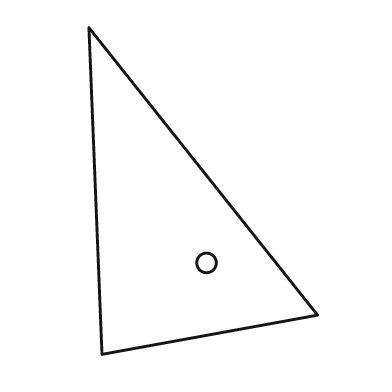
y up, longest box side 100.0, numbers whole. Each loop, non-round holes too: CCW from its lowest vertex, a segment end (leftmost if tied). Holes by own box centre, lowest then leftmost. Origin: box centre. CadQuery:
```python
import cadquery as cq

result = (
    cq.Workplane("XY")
    .moveTo(-31.0, -50.0)
    .lineTo(35.0, -38.0)
    .lineTo(-35.0, 50.0)
    .close()
    .moveTo(1.0, -22.0)
    .circle(3.0)
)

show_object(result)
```